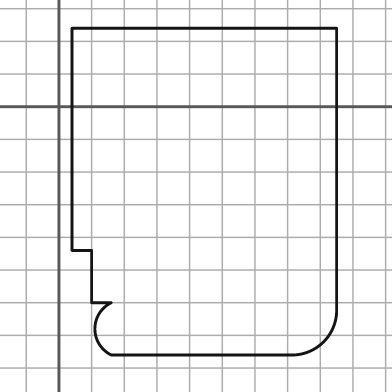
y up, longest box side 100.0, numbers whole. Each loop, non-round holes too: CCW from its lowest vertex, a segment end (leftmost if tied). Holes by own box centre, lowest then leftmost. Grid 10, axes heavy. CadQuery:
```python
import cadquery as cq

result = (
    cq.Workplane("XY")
    .moveTo(16.0, -76.0)
    .lineTo(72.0, -76.0)
    .threePointArc((81.0, -72.0), (85.0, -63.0))
    .lineTo(85.0, 24.0)
    .lineTo(4.0, 24.0)
    .lineTo(4.0, -44.0)
    .lineTo(10.0, -44.0)
    .lineTo(10.0, -60.0)
    .lineTo(16.0, -60.0)
    .threePointArc((11.0, -68.0), (16.0, -76.0))
    .close()
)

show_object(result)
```